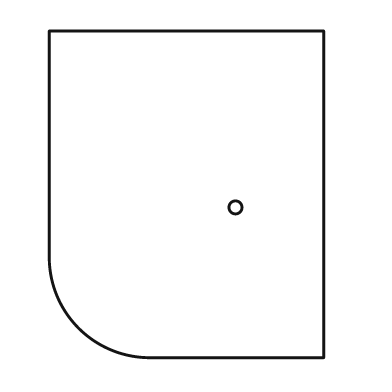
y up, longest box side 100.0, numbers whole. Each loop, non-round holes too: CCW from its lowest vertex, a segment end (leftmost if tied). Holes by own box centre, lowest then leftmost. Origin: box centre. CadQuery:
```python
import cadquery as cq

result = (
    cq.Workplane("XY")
    .moveTo(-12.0, -50.0)
    .lineTo(42.0, -50.0)
    .lineTo(42.0, 50.0)
    .lineTo(-42.0, 50.0)
    .lineTo(-42.0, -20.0)
    .threePointArc((-33.0, -41.0), (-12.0, -50.0))
    .close()
    .moveTo(15.0, -4.0)
    .circle(2.0)
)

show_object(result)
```